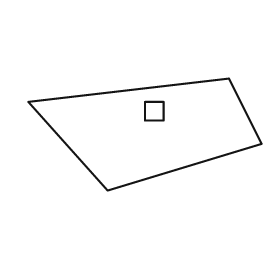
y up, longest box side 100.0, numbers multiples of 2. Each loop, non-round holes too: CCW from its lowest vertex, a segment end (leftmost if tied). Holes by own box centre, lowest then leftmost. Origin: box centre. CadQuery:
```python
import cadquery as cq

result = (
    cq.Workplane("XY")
    .moveTo(-16.0, -24.0)
    .lineTo(50.0, -4.0)
    .lineTo(36.0, 24.0)
    .lineTo(-50.0, 14.0)
    .close()
    .moveTo(0.0, 6.0)
    .lineTo(8.0, 6.0)
    .lineTo(8.0, 14.0)
    .lineTo(0.0, 14.0)
    .close()
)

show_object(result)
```